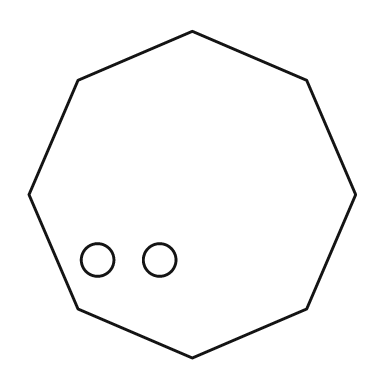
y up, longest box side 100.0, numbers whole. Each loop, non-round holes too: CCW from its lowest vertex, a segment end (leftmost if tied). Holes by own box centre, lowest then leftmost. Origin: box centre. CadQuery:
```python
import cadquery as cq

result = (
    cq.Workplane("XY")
    .moveTo(0.0, -50.0)
    .lineTo(35.0, -35.0)
    .lineTo(50.0, 0.0)
    .lineTo(35.0, 35.0)
    .lineTo(0.0, 50.0)
    .lineTo(-35.0, 35.0)
    .lineTo(-50.0, 0.0)
    .lineTo(-35.0, -35.0)
    .close()
    .moveTo(-29.0, -20.0)
    .circle(5.0)
    .moveTo(-10.0, -20.0)
    .circle(5.0)
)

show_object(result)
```